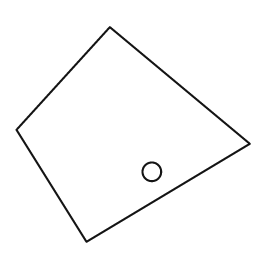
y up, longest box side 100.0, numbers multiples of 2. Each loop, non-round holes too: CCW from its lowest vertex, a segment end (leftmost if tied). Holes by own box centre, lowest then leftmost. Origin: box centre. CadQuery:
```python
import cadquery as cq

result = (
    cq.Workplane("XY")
    .moveTo(-20.0, -46.0)
    .lineTo(50.0, -4.0)
    .lineTo(-10.0, 46.0)
    .lineTo(-50.0, 2.0)
    .close()
    .moveTo(8.0, -16.0)
    .circle(4.0)
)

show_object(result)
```